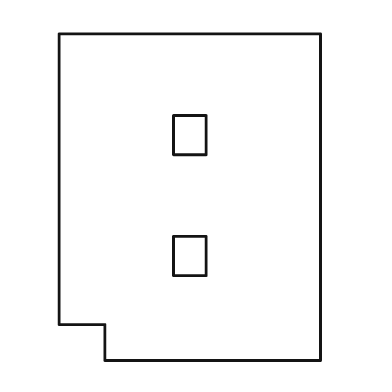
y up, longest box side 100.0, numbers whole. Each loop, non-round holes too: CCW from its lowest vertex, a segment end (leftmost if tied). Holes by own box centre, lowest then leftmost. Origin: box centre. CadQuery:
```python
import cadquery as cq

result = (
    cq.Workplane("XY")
    .moveTo(-26.0, -50.0)
    .lineTo(40.0, -50.0)
    .lineTo(40.0, 50.0)
    .lineTo(-40.0, 50.0)
    .lineTo(-40.0, -39.0)
    .lineTo(-26.0, -39.0)
    .close()
    .moveTo(-5.0, -24.0)
    .lineTo(5.0, -24.0)
    .lineTo(5.0, -12.0)
    .lineTo(-5.0, -12.0)
    .close()
    .moveTo(-5.0, 13.0)
    .lineTo(5.0, 13.0)
    .lineTo(5.0, 25.0)
    .lineTo(-5.0, 25.0)
    .close()
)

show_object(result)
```